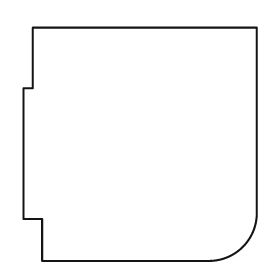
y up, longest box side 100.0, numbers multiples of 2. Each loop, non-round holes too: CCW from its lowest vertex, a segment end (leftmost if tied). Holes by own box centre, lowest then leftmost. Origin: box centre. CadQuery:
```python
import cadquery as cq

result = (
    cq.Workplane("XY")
    .moveTo(-42.0, -50.0)
    .lineTo(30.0, -50.0)
    .threePointArc((44.0, -44.0), (50.0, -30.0))
    .lineTo(50.0, 50.0)
    .lineTo(-46.0, 50.0)
    .lineTo(-46.0, 24.0)
    .lineTo(-50.0, 24.0)
    .lineTo(-50.0, -32.0)
    .lineTo(-42.0, -32.0)
    .close()
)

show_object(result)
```